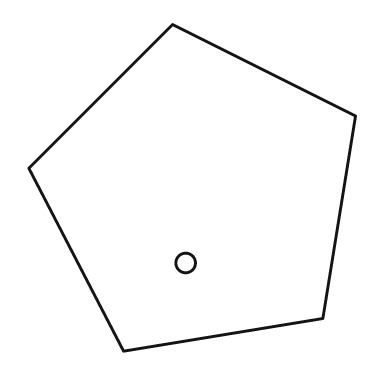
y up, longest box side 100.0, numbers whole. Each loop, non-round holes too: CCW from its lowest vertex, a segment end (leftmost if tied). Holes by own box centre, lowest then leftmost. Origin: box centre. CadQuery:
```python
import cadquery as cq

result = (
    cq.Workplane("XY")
    .moveTo(-21.0, -50.0)
    .lineTo(40.0, -40.0)
    .lineTo(50.0, 22.0)
    .lineTo(-6.0, 50.0)
    .lineTo(-50.0, 6.0)
    .close()
    .moveTo(-2.0, -23.0)
    .circle(3.0)
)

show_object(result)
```